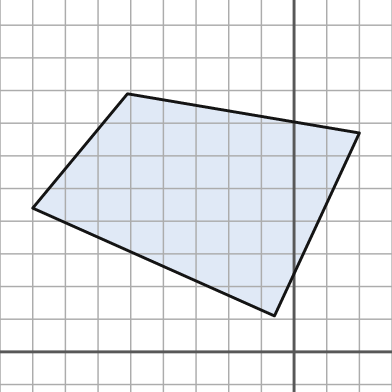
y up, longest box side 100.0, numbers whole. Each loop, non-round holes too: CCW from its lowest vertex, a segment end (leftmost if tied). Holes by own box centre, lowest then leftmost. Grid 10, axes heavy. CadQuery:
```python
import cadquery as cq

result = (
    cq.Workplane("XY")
    .moveTo(-6.0, 11.0)
    .lineTo(20.0, 67.0)
    .lineTo(-51.0, 79.0)
    .lineTo(-80.0, 44.0)
    .close()
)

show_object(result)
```